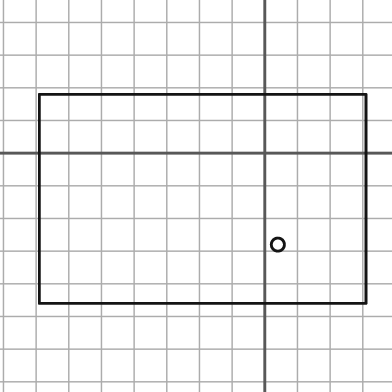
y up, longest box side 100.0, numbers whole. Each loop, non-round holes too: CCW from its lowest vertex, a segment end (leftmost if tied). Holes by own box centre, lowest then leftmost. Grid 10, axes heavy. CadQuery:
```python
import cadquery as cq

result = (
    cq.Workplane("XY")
    .moveTo(-69.0, -46.0)
    .lineTo(31.0, -46.0)
    .lineTo(31.0, 18.0)
    .lineTo(-69.0, 18.0)
    .close()
    .moveTo(4.0, -28.0)
    .circle(2.0)
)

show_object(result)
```